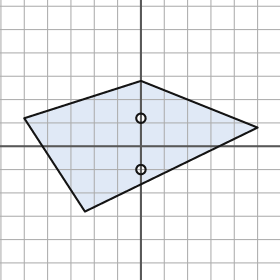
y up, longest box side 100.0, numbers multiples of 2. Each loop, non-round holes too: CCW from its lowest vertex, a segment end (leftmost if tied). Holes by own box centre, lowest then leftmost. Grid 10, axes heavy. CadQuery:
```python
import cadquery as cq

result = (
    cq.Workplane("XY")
    .moveTo(-24.0, -28.0)
    .lineTo(50.0, 8.0)
    .lineTo(0.0, 28.0)
    .lineTo(-50.0, 12.0)
    .close()
    .moveTo(0.0, -10.0)
    .circle(2.0)
    .moveTo(0.0, 12.0)
    .circle(2.0)
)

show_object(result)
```